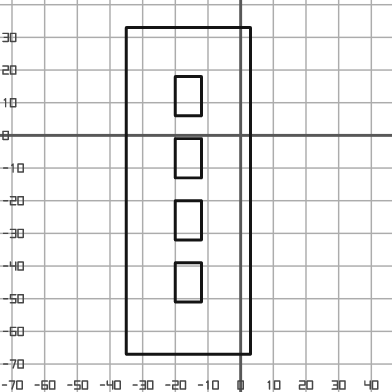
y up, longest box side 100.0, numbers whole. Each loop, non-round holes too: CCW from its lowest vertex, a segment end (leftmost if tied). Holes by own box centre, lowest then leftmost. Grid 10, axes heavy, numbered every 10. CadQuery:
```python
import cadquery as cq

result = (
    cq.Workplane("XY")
    .moveTo(-35.0, -67.0)
    .lineTo(3.0, -67.0)
    .lineTo(3.0, 33.0)
    .lineTo(-35.0, 33.0)
    .close()
    .moveTo(-20.0, -51.0)
    .lineTo(-12.0, -51.0)
    .lineTo(-12.0, -39.0)
    .lineTo(-20.0, -39.0)
    .close()
    .moveTo(-20.0, -32.0)
    .lineTo(-12.0, -32.0)
    .lineTo(-12.0, -20.0)
    .lineTo(-20.0, -20.0)
    .close()
    .moveTo(-20.0, -13.0)
    .lineTo(-12.0, -13.0)
    .lineTo(-12.0, -1.0)
    .lineTo(-20.0, -1.0)
    .close()
    .moveTo(-20.0, 6.0)
    .lineTo(-12.0, 6.0)
    .lineTo(-12.0, 18.0)
    .lineTo(-20.0, 18.0)
    .close()
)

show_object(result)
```